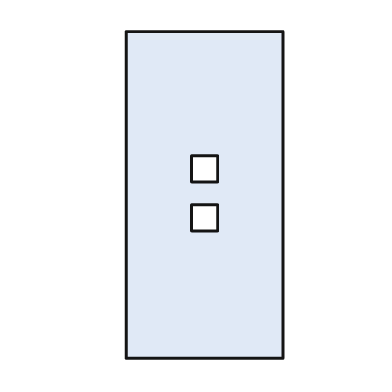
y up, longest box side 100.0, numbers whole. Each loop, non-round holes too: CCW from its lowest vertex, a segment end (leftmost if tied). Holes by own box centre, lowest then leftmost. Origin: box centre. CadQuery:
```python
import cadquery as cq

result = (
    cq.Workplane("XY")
    .moveTo(-24.0, -50.0)
    .lineTo(24.0, -50.0)
    .lineTo(24.0, 50.0)
    .lineTo(-24.0, 50.0)
    .close()
    .moveTo(-4.0, -11.0)
    .lineTo(4.0, -11.0)
    .lineTo(4.0, -3.0)
    .lineTo(-4.0, -3.0)
    .close()
    .moveTo(-4.0, 4.0)
    .lineTo(4.0, 4.0)
    .lineTo(4.0, 12.0)
    .lineTo(-4.0, 12.0)
    .close()
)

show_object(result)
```